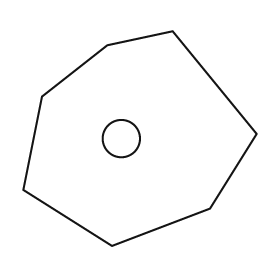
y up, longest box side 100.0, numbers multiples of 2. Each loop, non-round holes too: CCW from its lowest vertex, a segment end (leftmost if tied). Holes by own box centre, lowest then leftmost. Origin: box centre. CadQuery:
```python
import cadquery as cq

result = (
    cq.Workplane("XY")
    .moveTo(-12.0, -46.0)
    .lineTo(30.0, -30.0)
    .lineTo(50.0, 2.0)
    .lineTo(14.0, 46.0)
    .lineTo(-14.0, 40.0)
    .lineTo(-42.0, 18.0)
    .lineTo(-50.0, -22.0)
    .close()
    .moveTo(-8.0, 0.0)
    .circle(8.0)
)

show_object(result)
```